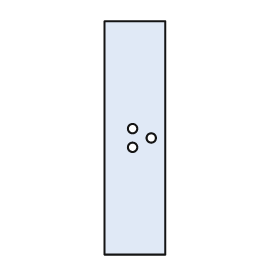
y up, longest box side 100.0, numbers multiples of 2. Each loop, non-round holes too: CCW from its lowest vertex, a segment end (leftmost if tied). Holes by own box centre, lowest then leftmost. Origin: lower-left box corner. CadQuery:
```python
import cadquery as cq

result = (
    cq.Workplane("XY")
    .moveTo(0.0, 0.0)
    .lineTo(26.0, 0.0)
    .lineTo(26.0, 100.0)
    .lineTo(0.0, 100.0)
    .close()
    .moveTo(12.0, 46.0)
    .circle(2.0)
    .moveTo(20.0, 50.0)
    .circle(2.0)
    .moveTo(12.0, 54.0)
    .circle(2.0)
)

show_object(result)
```